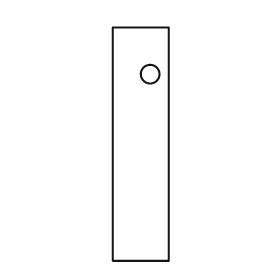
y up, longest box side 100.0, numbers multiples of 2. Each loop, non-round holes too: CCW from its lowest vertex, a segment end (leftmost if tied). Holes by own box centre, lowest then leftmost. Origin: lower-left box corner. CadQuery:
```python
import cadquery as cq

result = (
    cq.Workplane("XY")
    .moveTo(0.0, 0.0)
    .lineTo(24.0, 0.0)
    .lineTo(24.0, 100.0)
    .lineTo(0.0, 100.0)
    .close()
    .moveTo(16.0, 80.0)
    .circle(4.0)
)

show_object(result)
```